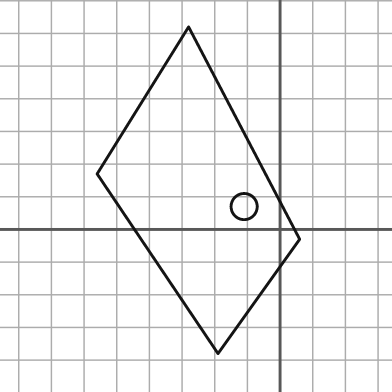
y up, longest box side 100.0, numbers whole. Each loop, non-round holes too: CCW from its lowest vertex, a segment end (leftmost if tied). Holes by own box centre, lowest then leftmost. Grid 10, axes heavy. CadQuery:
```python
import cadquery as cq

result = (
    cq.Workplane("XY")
    .moveTo(-19.0, -38.0)
    .lineTo(6.0, -3.0)
    .lineTo(-28.0, 62.0)
    .lineTo(-56.0, 17.0)
    .close()
    .moveTo(-11.0, 7.0)
    .circle(4.0)
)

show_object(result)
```